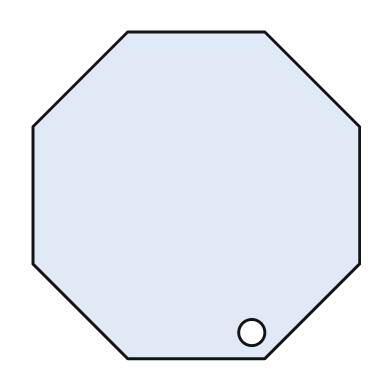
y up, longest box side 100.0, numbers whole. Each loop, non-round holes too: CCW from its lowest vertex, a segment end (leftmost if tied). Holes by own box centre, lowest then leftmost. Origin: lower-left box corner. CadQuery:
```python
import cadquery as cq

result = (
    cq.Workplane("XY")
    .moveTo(29.0, 0.0)
    .lineTo(71.0, 0.0)
    .lineTo(100.0, 29.0)
    .lineTo(100.0, 71.0)
    .lineTo(71.0, 100.0)
    .lineTo(29.0, 100.0)
    .lineTo(0.0, 71.0)
    .lineTo(0.0, 29.0)
    .close()
    .moveTo(67.0, 8.0)
    .circle(4.0)
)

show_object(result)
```